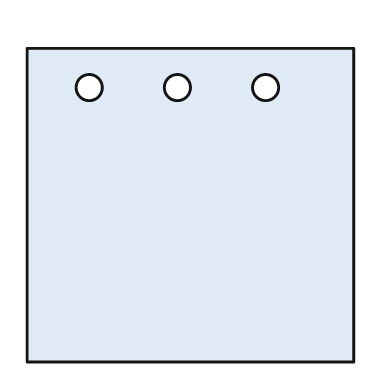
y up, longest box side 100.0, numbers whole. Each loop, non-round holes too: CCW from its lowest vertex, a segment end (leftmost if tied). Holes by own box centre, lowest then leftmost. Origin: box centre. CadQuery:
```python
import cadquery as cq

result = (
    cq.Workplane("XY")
    .moveTo(-50.0, -48.0)
    .lineTo(50.0, -48.0)
    .lineTo(50.0, 48.0)
    .lineTo(-50.0, 48.0)
    .close()
    .moveTo(-31.0, 36.0)
    .circle(4.0)
    .moveTo(-4.0, 36.0)
    .circle(4.0)
    .moveTo(23.0, 36.0)
    .circle(4.0)
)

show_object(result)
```